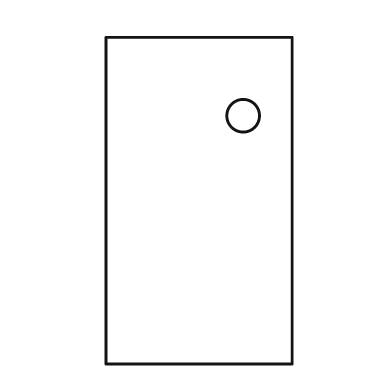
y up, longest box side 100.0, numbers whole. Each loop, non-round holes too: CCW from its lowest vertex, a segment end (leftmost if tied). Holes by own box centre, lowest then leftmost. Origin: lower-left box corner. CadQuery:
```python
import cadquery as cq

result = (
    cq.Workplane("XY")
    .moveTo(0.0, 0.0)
    .lineTo(57.0, 0.0)
    .lineTo(57.0, 100.0)
    .lineTo(0.0, 100.0)
    .close()
    .moveTo(42.0, 76.0)
    .circle(5.0)
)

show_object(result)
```